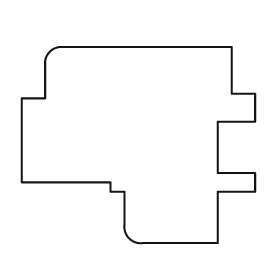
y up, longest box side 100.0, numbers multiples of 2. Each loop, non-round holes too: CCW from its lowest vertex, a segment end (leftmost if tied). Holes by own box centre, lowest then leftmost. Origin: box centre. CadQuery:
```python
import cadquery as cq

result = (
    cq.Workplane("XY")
    .moveTo(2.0, -42.0)
    .lineTo(34.0, -42.0)
    .lineTo(34.0, -20.0)
    .lineTo(50.0, -20.0)
    .lineTo(50.0, -12.0)
    .lineTo(34.0, -12.0)
    .lineTo(34.0, 10.0)
    .lineTo(50.0, 10.0)
    .lineTo(50.0, 22.0)
    .lineTo(40.0, 22.0)
    .lineTo(40.0, 42.0)
    .lineTo(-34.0, 42.0)
    .threePointArc((-38.0, 40.0), (-40.0, 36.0))
    .lineTo(-40.0, 20.0)
    .lineTo(-50.0, 20.0)
    .lineTo(-50.0, -16.0)
    .lineTo(-12.0, -16.0)
    .lineTo(-12.0, -20.0)
    .lineTo(-6.0, -20.0)
    .lineTo(-6.0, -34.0)
    .threePointArc((-4.0, -40.0), (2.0, -42.0))
    .close()
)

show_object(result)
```